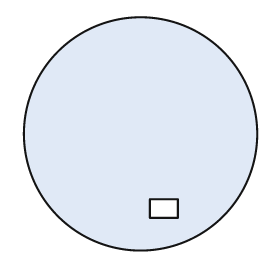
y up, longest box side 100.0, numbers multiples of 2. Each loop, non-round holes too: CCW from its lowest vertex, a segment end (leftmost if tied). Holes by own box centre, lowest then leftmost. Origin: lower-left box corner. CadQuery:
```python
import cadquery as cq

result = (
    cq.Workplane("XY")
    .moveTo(50.0, 50.0)
    .circle(50.0)
    .moveTo(54.0, 14.0)
    .lineTo(66.0, 14.0)
    .lineTo(66.0, 22.0)
    .lineTo(54.0, 22.0)
    .close()
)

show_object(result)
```